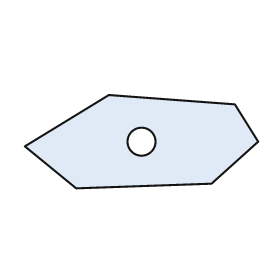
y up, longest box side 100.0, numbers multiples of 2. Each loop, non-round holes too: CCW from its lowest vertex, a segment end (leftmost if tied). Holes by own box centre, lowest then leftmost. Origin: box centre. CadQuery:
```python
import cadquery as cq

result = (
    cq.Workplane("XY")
    .moveTo(-28.0, -20.0)
    .lineTo(30.0, -18.0)
    .lineTo(50.0, 0.0)
    .lineTo(40.0, 16.0)
    .lineTo(-14.0, 20.0)
    .lineTo(-50.0, -2.0)
    .close()
    .moveTo(0.0, 0.0)
    .circle(6.0)
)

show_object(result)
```